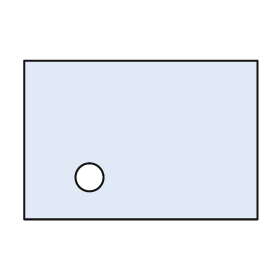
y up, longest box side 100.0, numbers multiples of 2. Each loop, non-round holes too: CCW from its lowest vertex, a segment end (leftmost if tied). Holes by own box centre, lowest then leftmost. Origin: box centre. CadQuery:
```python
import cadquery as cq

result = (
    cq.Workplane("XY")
    .moveTo(-50.0, -34.0)
    .lineTo(50.0, -34.0)
    .lineTo(50.0, 34.0)
    .lineTo(-50.0, 34.0)
    .close()
    .moveTo(-22.0, -16.0)
    .circle(6.0)
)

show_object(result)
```